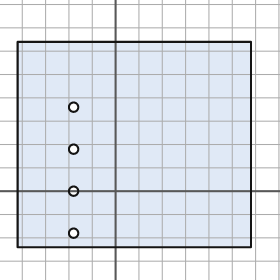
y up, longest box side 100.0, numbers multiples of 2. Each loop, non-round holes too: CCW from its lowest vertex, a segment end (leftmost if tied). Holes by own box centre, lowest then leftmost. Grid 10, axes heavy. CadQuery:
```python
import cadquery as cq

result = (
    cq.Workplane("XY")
    .moveTo(-42.0, -24.0)
    .lineTo(58.0, -24.0)
    .lineTo(58.0, 64.0)
    .lineTo(-42.0, 64.0)
    .close()
    .moveTo(-18.0, -18.0)
    .circle(2.0)
    .moveTo(-18.0, 0.0)
    .circle(2.0)
    .moveTo(-18.0, 18.0)
    .circle(2.0)
    .moveTo(-18.0, 36.0)
    .circle(2.0)
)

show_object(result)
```